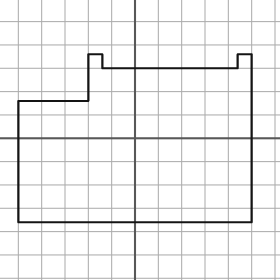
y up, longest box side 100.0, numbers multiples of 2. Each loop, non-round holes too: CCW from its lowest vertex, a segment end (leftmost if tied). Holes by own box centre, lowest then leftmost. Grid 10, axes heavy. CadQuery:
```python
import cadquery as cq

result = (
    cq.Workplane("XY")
    .moveTo(-50.0, -36.0)
    .lineTo(50.0, -36.0)
    .lineTo(50.0, 36.0)
    .lineTo(44.0, 36.0)
    .lineTo(44.0, 30.0)
    .lineTo(-14.0, 30.0)
    .lineTo(-14.0, 36.0)
    .lineTo(-20.0, 36.0)
    .lineTo(-20.0, 16.0)
    .lineTo(-50.0, 16.0)
    .close()
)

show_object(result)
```